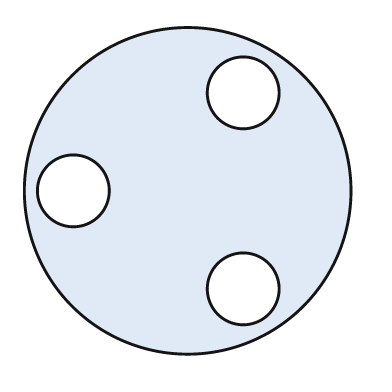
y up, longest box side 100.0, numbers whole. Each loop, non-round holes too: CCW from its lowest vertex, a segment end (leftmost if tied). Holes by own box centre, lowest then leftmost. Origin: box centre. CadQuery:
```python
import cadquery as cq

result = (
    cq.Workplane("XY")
    .moveTo(0.0, 0.0)
    .circle(50.0)
    .moveTo(17.0, -30.0)
    .circle(11.0)
    .moveTo(-35.0, 0.0)
    .circle(11.0)
    .moveTo(17.0, 30.0)
    .circle(11.0)
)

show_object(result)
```